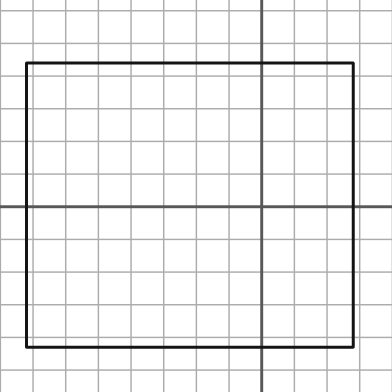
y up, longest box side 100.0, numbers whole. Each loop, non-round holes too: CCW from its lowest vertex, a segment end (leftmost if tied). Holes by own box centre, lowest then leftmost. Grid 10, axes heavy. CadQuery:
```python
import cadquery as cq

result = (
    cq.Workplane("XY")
    .moveTo(-72.0, -43.0)
    .lineTo(28.0, -43.0)
    .lineTo(28.0, 44.0)
    .lineTo(-72.0, 44.0)
    .close()
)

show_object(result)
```